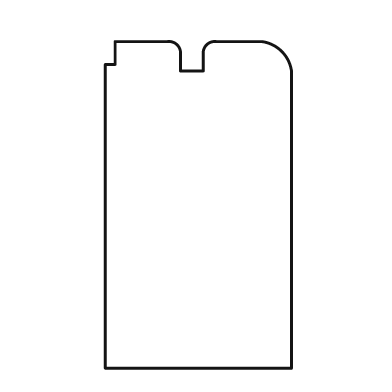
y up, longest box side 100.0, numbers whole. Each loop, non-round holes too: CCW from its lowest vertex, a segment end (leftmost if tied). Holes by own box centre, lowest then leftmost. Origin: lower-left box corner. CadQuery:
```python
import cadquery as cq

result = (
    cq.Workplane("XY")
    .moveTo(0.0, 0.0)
    .lineTo(57.0, 0.0)
    .lineTo(57.0, 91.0)
    .threePointArc((54.0, 97.0), (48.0, 100.0))
    .lineTo(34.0, 100.0)
    .threePointArc((31.0, 99.0), (30.0, 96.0))
    .lineTo(30.0, 91.0)
    .lineTo(23.0, 91.0)
    .lineTo(23.0, 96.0)
    .threePointArc((22.0, 99.0), (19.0, 100.0))
    .lineTo(3.0, 100.0)
    .lineTo(3.0, 93.0)
    .lineTo(0.0, 93.0)
    .close()
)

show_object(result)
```